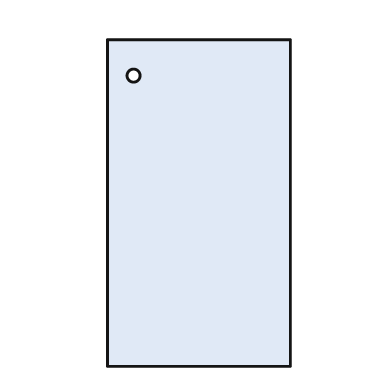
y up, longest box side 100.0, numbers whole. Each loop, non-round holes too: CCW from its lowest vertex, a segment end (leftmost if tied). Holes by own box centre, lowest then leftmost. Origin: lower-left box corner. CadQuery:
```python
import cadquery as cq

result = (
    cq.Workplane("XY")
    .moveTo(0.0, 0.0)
    .lineTo(56.0, 0.0)
    .lineTo(56.0, 100.0)
    .lineTo(0.0, 100.0)
    .close()
    .moveTo(8.0, 89.0)
    .circle(2.0)
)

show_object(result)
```